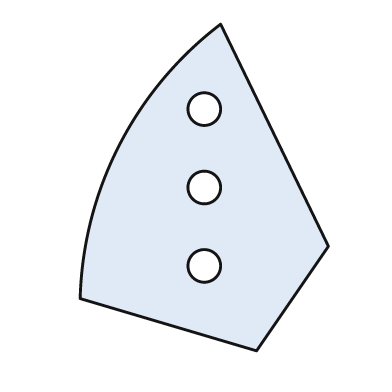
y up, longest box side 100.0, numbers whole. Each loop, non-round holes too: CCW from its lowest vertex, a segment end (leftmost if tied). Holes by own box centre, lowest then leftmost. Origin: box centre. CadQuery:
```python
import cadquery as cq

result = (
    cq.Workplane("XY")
    .moveTo(16.0, -50.0)
    .lineTo(38.0, -18.0)
    .lineTo(5.0, 50.0)
    .threePointArc((-26.0, 13.0), (-38.0, -34.0))
    .close()
    .moveTo(0.0, -24.0)
    .circle(5.0)
    .moveTo(0.0, 0.0)
    .circle(5.0)
    .moveTo(0.0, 24.0)
    .circle(5.0)
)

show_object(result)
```